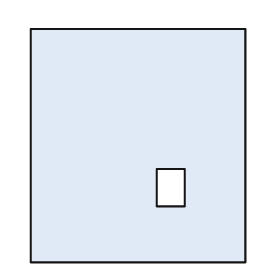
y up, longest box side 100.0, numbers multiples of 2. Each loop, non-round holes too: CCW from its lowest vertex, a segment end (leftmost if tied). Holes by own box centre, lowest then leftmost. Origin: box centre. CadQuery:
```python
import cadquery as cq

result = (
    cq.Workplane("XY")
    .moveTo(-46.0, -50.0)
    .lineTo(46.0, -50.0)
    .lineTo(46.0, 50.0)
    .lineTo(-46.0, 50.0)
    .close()
    .moveTo(8.0, -26.0)
    .lineTo(20.0, -26.0)
    .lineTo(20.0, -10.0)
    .lineTo(8.0, -10.0)
    .close()
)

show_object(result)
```